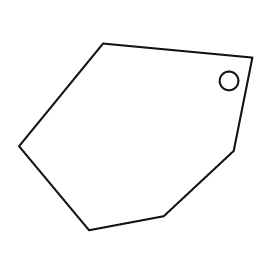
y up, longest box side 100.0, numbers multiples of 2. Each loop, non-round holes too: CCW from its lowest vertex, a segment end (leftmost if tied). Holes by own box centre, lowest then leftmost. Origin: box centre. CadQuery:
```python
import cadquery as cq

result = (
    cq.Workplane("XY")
    .moveTo(-20.0, -40.0)
    .lineTo(12.0, -34.0)
    .lineTo(42.0, -6.0)
    .lineTo(50.0, 34.0)
    .lineTo(-14.0, 40.0)
    .lineTo(-50.0, -4.0)
    .close()
    .moveTo(40.0, 24.0)
    .circle(4.0)
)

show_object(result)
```